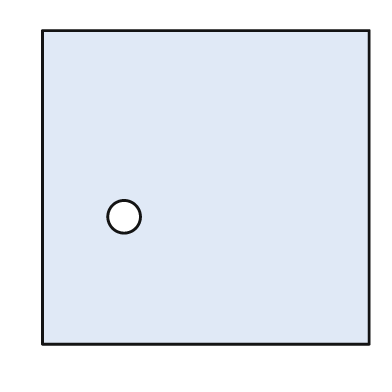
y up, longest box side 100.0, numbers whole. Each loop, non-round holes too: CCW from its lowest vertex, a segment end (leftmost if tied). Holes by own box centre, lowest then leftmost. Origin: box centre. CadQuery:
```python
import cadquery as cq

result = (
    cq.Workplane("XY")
    .moveTo(-50.0, -48.0)
    .lineTo(50.0, -48.0)
    .lineTo(50.0, 48.0)
    .lineTo(-50.0, 48.0)
    .close()
    .moveTo(-25.0, -9.0)
    .circle(5.0)
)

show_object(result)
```